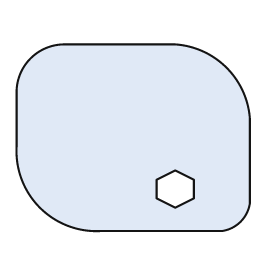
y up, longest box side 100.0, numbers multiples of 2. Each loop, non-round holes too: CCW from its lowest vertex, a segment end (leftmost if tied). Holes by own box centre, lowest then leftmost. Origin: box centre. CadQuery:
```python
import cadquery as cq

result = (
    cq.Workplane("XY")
    .moveTo(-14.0, -40.0)
    .lineTo(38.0, -40.0)
    .threePointArc((46.0, -36.0), (50.0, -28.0))
    .lineTo(50.0, 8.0)
    .threePointArc((40.0, 30.0), (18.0, 40.0))
    .lineTo(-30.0, 40.0)
    .threePointArc((-44.0, 34.0), (-50.0, 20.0))
    .lineTo(-50.0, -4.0)
    .threePointArc((-40.0, -30.0), (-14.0, -40.0))
    .close()
    .moveTo(18.0, -30.0)
    .lineTo(26.0, -26.0)
    .lineTo(26.0, -18.0)
    .lineTo(18.0, -14.0)
    .lineTo(10.0, -18.0)
    .lineTo(10.0, -26.0)
    .close()
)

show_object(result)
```